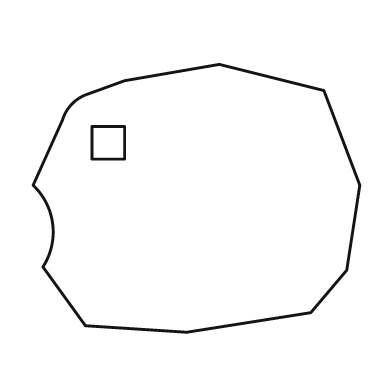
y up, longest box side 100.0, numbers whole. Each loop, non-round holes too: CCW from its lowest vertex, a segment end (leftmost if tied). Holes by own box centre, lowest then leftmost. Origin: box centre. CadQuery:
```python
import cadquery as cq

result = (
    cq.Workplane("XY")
    .moveTo(-3.0, -41.0)
    .lineTo(35.0, -35.0)
    .lineTo(46.0, -22.0)
    .lineTo(50.0, 4.0)
    .lineTo(39.0, 33.0)
    .lineTo(7.0, 41.0)
    .lineTo(-22.0, 36.0)
    .lineTo(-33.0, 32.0)
    .threePointArc((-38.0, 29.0), (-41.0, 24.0))
    .lineTo(-50.0, 4.0)
    .threePointArc((-44.0, -8.0), (-47.0, -21.0))
    .lineTo(-34.0, -39.0)
    .close()
    .moveTo(-32.0, 12.0)
    .lineTo(-22.0, 12.0)
    .lineTo(-22.0, 22.0)
    .lineTo(-32.0, 22.0)
    .close()
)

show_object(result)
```